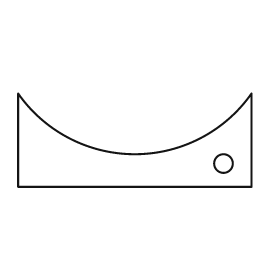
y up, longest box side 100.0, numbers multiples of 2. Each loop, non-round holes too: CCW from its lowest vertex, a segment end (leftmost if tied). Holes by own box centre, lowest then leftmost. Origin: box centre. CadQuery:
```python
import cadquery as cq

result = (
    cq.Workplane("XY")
    .moveTo(-50.0, -20.0)
    .lineTo(50.0, -20.0)
    .lineTo(50.0, 20.0)
    .threePointArc((0.0, -6.0), (-50.0, 20.0))
    .close()
    .moveTo(38.0, -10.0)
    .circle(4.0)
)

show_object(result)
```